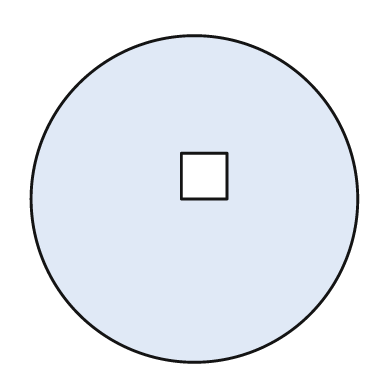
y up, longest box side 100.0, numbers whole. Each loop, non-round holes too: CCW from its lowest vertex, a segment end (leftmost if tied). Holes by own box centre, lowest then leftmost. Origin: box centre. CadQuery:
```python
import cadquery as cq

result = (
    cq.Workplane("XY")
    .moveTo(0.0, 0.0)
    .circle(50.0)
    .moveTo(-4.0, 0.0)
    .lineTo(10.0, 0.0)
    .lineTo(10.0, 14.0)
    .lineTo(-4.0, 14.0)
    .close()
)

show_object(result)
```